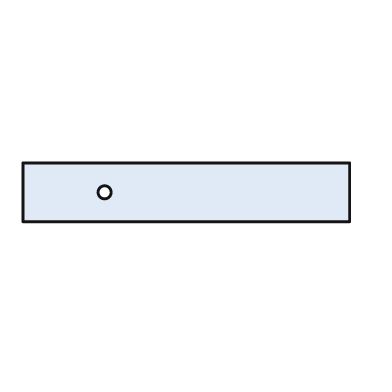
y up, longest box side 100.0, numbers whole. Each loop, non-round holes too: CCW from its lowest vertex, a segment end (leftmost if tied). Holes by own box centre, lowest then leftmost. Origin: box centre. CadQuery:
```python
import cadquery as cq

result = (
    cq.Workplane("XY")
    .moveTo(-50.0, -9.0)
    .lineTo(50.0, -9.0)
    .lineTo(50.0, 9.0)
    .lineTo(-50.0, 9.0)
    .close()
    .moveTo(-25.0, 0.0)
    .circle(2.0)
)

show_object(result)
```